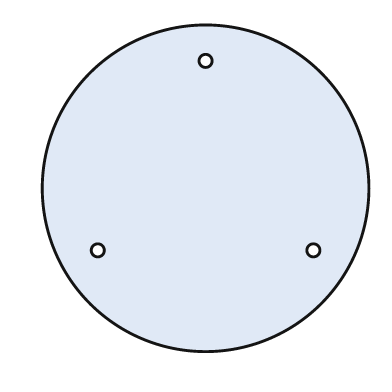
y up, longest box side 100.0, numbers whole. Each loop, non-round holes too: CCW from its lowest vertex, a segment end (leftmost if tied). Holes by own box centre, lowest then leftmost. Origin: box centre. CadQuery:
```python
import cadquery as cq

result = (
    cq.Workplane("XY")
    .moveTo(0.0, 0.0)
    .circle(50.0)
    .moveTo(-33.0, -19.0)
    .circle(2.0)
    .moveTo(33.0, -19.0)
    .circle(2.0)
    .moveTo(0.0, 39.0)
    .circle(2.0)
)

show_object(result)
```